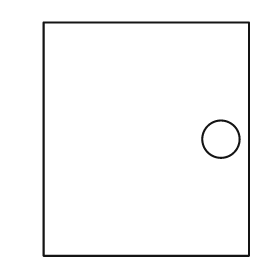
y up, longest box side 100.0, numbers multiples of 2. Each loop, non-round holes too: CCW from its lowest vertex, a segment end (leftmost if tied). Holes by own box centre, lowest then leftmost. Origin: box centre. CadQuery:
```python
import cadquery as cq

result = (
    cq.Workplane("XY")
    .moveTo(-44.0, -50.0)
    .lineTo(44.0, -50.0)
    .lineTo(44.0, 50.0)
    .lineTo(-44.0, 50.0)
    .close()
    .moveTo(32.0, 0.0)
    .circle(8.0)
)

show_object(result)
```